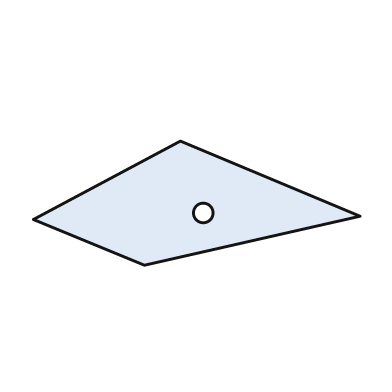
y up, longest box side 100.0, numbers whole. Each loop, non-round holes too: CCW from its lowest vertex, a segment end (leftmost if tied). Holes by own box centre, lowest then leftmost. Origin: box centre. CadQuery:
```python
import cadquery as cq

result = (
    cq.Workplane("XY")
    .moveTo(-16.0, -19.0)
    .lineTo(50.0, -4.0)
    .lineTo(-5.0, 19.0)
    .lineTo(-50.0, -5.0)
    .close()
    .moveTo(2.0, -3.0)
    .circle(3.0)
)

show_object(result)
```